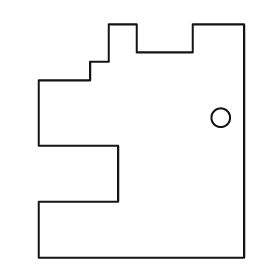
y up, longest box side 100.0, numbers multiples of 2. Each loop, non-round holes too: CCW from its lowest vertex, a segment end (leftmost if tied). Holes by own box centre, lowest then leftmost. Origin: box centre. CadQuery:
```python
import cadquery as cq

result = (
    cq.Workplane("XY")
    .moveTo(-44.0, -50.0)
    .lineTo(44.0, -50.0)
    .lineTo(44.0, 50.0)
    .lineTo(22.0, 50.0)
    .lineTo(22.0, 38.0)
    .lineTo(-2.0, 38.0)
    .lineTo(-2.0, 50.0)
    .lineTo(-14.0, 50.0)
    .lineTo(-14.0, 34.0)
    .lineTo(-22.0, 34.0)
    .lineTo(-22.0, 26.0)
    .lineTo(-44.0, 26.0)
    .lineTo(-44.0, -2.0)
    .lineTo(-10.0, -2.0)
    .lineTo(-10.0, -26.0)
    .lineTo(-44.0, -26.0)
    .close()
    .moveTo(34.0, 10.0)
    .circle(4.0)
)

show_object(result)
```